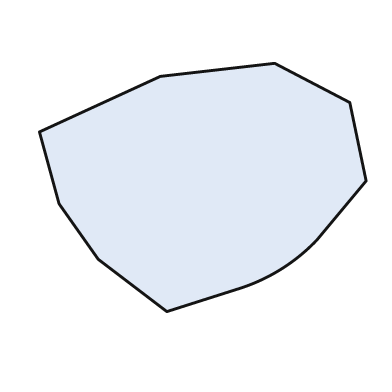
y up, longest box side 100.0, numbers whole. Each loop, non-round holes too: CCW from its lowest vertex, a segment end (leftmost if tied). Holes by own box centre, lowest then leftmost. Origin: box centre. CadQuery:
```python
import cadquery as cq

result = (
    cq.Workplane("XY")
    .moveTo(-11.0, -38.0)
    .lineTo(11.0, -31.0)
    .threePointArc((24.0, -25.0), (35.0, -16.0))
    .lineTo(50.0, 2.0)
    .lineTo(45.0, 26.0)
    .lineTo(22.0, 38.0)
    .lineTo(-13.0, 34.0)
    .lineTo(-50.0, 17.0)
    .lineTo(-44.0, -5.0)
    .lineTo(-32.0, -22.0)
    .close()
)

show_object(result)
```